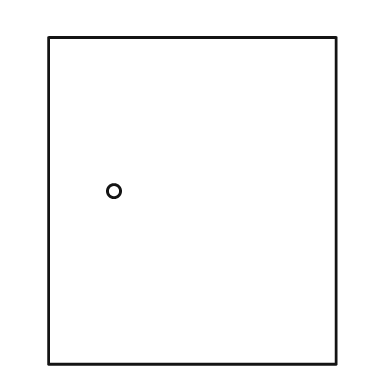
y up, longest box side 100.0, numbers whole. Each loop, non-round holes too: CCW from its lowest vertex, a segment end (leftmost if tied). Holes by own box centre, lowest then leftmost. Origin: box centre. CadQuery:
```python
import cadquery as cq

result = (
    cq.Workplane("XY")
    .moveTo(-44.0, -50.0)
    .lineTo(44.0, -50.0)
    .lineTo(44.0, 50.0)
    .lineTo(-44.0, 50.0)
    .close()
    .moveTo(-24.0, 3.0)
    .circle(2.0)
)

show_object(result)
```